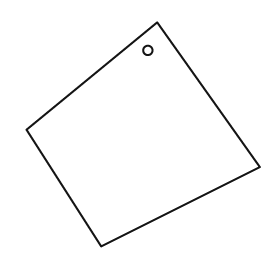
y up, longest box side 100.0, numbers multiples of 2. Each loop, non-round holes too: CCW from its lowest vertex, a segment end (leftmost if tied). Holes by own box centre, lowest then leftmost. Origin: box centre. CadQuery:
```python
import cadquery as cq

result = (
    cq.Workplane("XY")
    .moveTo(-18.0, -48.0)
    .lineTo(50.0, -14.0)
    .lineTo(6.0, 48.0)
    .lineTo(-50.0, 2.0)
    .close()
    .moveTo(2.0, 36.0)
    .circle(2.0)
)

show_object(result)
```